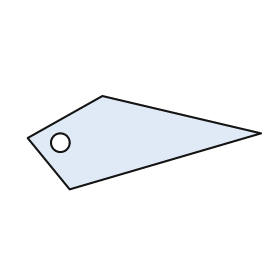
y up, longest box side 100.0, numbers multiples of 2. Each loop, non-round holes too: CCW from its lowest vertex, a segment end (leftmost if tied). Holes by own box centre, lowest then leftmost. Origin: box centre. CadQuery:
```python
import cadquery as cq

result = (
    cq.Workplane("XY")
    .moveTo(-32.0, -20.0)
    .lineTo(50.0, 4.0)
    .lineTo(-18.0, 20.0)
    .lineTo(-50.0, 2.0)
    .close()
    .moveTo(-36.0, 0.0)
    .circle(4.0)
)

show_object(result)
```